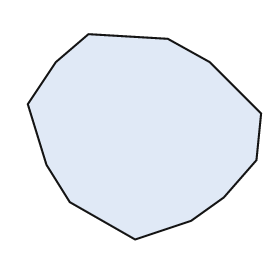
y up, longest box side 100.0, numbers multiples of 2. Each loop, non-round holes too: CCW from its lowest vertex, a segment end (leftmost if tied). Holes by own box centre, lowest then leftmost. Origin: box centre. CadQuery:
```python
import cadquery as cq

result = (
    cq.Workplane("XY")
    .moveTo(-4.0, -44.0)
    .lineTo(20.0, -36.0)
    .lineTo(34.0, -26.0)
    .lineTo(48.0, -10.0)
    .lineTo(50.0, 10.0)
    .lineTo(28.0, 32.0)
    .lineTo(10.0, 42.0)
    .lineTo(-24.0, 44.0)
    .lineTo(-38.0, 32.0)
    .lineTo(-50.0, 14.0)
    .lineTo(-42.0, -12.0)
    .lineTo(-32.0, -28.0)
    .close()
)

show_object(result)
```